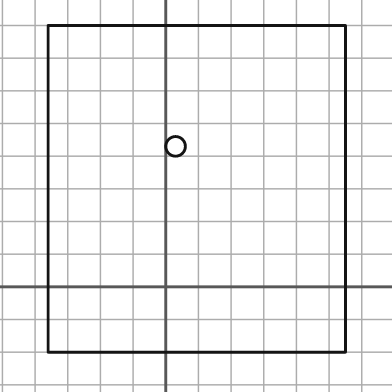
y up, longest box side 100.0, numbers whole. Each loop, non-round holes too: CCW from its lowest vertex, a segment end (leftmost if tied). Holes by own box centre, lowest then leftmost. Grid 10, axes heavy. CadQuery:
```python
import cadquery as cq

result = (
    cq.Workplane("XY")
    .moveTo(-36.0, -20.0)
    .lineTo(55.0, -20.0)
    .lineTo(55.0, 80.0)
    .lineTo(-36.0, 80.0)
    .close()
    .moveTo(3.0, 43.0)
    .circle(3.0)
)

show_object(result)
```